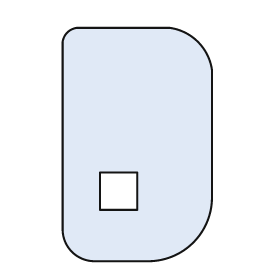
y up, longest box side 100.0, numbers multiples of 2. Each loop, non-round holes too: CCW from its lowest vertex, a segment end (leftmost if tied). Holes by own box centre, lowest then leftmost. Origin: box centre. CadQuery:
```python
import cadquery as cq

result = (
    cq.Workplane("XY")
    .moveTo(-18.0, -50.0)
    .lineTo(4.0, -50.0)
    .threePointArc((24.0, -42.0), (32.0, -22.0))
    .lineTo(32.0, 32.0)
    .threePointArc((26.0, 44.0), (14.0, 50.0))
    .lineTo(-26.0, 50.0)
    .threePointArc((-30.0, 48.0), (-32.0, 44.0))
    .lineTo(-32.0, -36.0)
    .threePointArc((-28.0, -46.0), (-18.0, -50.0))
    .close()
    .moveTo(-16.0, -28.0)
    .lineTo(0.0, -28.0)
    .lineTo(0.0, -12.0)
    .lineTo(-16.0, -12.0)
    .close()
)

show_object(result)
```